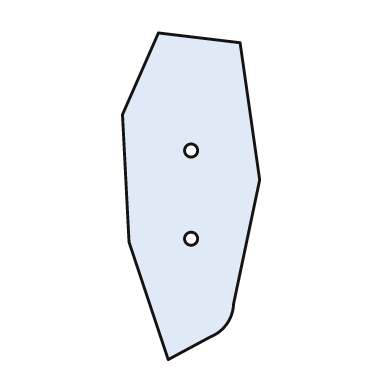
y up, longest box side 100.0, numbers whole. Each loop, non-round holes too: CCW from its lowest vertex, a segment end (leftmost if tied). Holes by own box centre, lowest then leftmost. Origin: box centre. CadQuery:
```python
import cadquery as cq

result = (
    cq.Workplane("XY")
    .moveTo(-7.0, -50.0)
    .lineTo(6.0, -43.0)
    .threePointArc((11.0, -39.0), (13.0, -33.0))
    .lineTo(21.0, 5.0)
    .lineTo(15.0, 47.0)
    .lineTo(-10.0, 50.0)
    .lineTo(-21.0, 25.0)
    .lineTo(-19.0, -14.0)
    .close()
    .moveTo(0.0, -13.0)
    .circle(2.0)
    .moveTo(0.0, 14.0)
    .circle(2.0)
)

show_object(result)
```